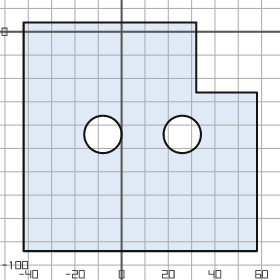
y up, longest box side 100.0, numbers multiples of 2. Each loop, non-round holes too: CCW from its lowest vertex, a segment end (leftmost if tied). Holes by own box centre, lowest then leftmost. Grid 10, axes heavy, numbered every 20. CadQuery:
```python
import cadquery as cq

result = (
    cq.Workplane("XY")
    .moveTo(-42.0, -94.0)
    .lineTo(58.0, -94.0)
    .lineTo(58.0, -26.0)
    .lineTo(32.0, -26.0)
    .lineTo(32.0, 4.0)
    .lineTo(-42.0, 4.0)
    .close()
    .moveTo(-8.0, -44.0)
    .circle(8.0)
    .moveTo(26.0, -44.0)
    .circle(8.0)
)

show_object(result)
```